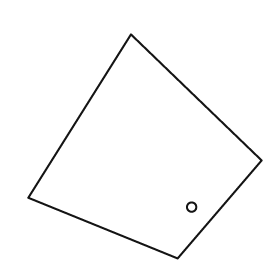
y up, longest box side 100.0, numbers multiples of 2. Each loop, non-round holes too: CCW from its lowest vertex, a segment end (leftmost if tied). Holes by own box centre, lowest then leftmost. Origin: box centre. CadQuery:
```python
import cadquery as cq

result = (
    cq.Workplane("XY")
    .moveTo(14.0, -48.0)
    .lineTo(50.0, -6.0)
    .lineTo(-6.0, 48.0)
    .lineTo(-50.0, -22.0)
    .close()
    .moveTo(20.0, -26.0)
    .circle(2.0)
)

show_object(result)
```